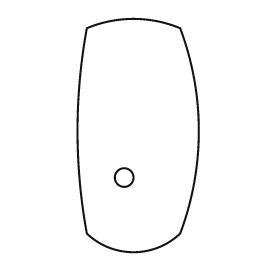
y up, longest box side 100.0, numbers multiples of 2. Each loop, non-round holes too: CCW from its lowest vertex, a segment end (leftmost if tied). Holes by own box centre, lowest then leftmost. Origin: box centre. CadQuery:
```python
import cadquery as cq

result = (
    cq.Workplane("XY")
    .moveTo(-22.0, -42.0)
    .threePointArc((-2.0, -50.0), (18.0, -42.0))
    .threePointArc((26.0, 2.0), (18.0, 46.0))
    .threePointArc((-2.0, 50.0), (-22.0, 46.0))
    .threePointArc((-26.0, 2.0), (-22.0, -42.0))
    .close()
    .moveTo(-6.0, -18.0)
    .circle(4.0)
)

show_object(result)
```